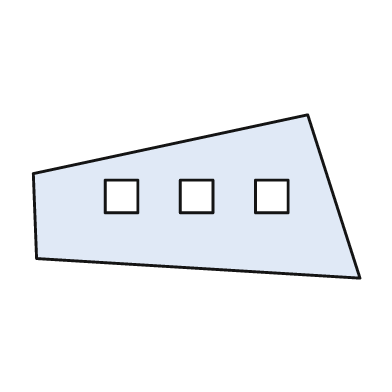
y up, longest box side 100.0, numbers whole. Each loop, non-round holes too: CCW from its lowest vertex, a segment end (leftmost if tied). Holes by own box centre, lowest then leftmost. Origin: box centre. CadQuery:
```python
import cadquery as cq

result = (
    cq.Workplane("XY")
    .moveTo(50.0, -25.0)
    .lineTo(34.0, 25.0)
    .lineTo(-50.0, 7.0)
    .lineTo(-49.0, -19.0)
    .close()
    .moveTo(-28.0, -5.0)
    .lineTo(-18.0, -5.0)
    .lineTo(-18.0, 5.0)
    .lineTo(-28.0, 5.0)
    .close()
    .moveTo(-5.0, -5.0)
    .lineTo(5.0, -5.0)
    .lineTo(5.0, 5.0)
    .lineTo(-5.0, 5.0)
    .close()
    .moveTo(18.0, -5.0)
    .lineTo(28.0, -5.0)
    .lineTo(28.0, 5.0)
    .lineTo(18.0, 5.0)
    .close()
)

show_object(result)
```